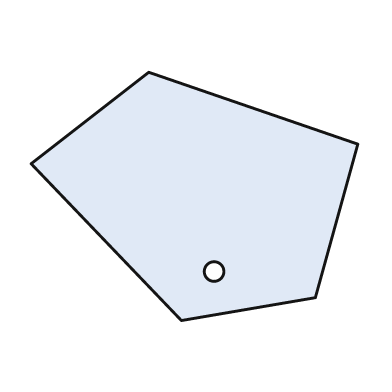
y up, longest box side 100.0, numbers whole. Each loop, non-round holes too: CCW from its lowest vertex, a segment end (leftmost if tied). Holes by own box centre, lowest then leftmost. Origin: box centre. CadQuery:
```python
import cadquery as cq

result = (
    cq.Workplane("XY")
    .moveTo(-4.0, -38.0)
    .lineTo(37.0, -31.0)
    .lineTo(50.0, 16.0)
    .lineTo(-14.0, 38.0)
    .lineTo(-50.0, 10.0)
    .close()
    .moveTo(6.0, -23.0)
    .circle(3.0)
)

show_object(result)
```